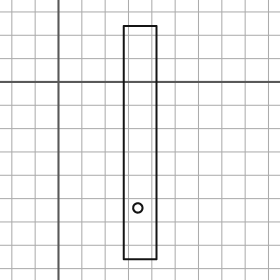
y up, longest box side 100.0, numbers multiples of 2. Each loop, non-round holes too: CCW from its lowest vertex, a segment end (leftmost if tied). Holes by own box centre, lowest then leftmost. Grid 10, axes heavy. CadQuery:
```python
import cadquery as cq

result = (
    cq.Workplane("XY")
    .moveTo(28.0, -76.0)
    .lineTo(42.0, -76.0)
    .lineTo(42.0, 24.0)
    .lineTo(28.0, 24.0)
    .close()
    .moveTo(34.0, -54.0)
    .circle(2.0)
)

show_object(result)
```